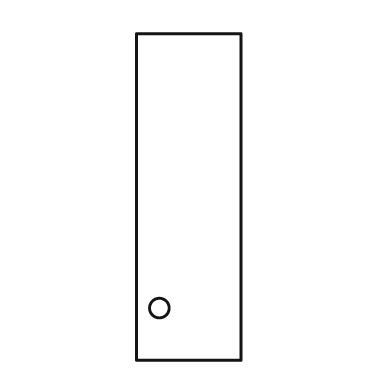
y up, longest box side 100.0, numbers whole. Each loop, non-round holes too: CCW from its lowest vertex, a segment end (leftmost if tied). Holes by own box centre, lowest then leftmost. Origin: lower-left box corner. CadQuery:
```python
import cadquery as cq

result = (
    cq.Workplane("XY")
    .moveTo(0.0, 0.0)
    .lineTo(32.0, 0.0)
    .lineTo(32.0, 100.0)
    .lineTo(0.0, 100.0)
    .close()
    .moveTo(7.0, 16.0)
    .circle(3.0)
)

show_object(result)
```